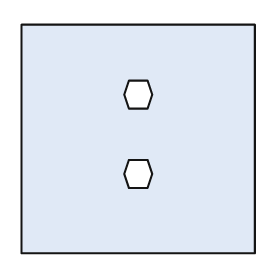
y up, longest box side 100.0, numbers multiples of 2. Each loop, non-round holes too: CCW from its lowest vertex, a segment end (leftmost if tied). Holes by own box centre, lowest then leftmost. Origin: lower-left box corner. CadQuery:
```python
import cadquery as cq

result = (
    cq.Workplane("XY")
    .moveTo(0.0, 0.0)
    .lineTo(100.0, 0.0)
    .lineTo(100.0, 98.0)
    .lineTo(0.0, 98.0)
    .close()
    .moveTo(46.0, 28.0)
    .lineTo(54.0, 28.0)
    .lineTo(56.0, 34.0)
    .lineTo(54.0, 40.0)
    .lineTo(46.0, 40.0)
    .lineTo(44.0, 34.0)
    .close()
    .moveTo(46.0, 62.0)
    .lineTo(54.0, 62.0)
    .lineTo(56.0, 68.0)
    .lineTo(54.0, 74.0)
    .lineTo(46.0, 74.0)
    .lineTo(44.0, 68.0)
    .close()
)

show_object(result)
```